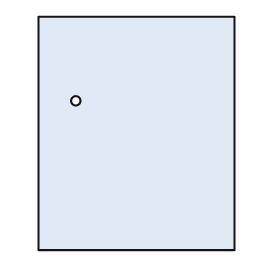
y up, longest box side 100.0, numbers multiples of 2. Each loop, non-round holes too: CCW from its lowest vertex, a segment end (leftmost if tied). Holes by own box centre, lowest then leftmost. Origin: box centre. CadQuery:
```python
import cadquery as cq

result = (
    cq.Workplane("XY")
    .moveTo(-42.0, -50.0)
    .lineTo(42.0, -50.0)
    .lineTo(42.0, 50.0)
    .lineTo(-42.0, 50.0)
    .close()
    .moveTo(-26.0, 14.0)
    .circle(2.0)
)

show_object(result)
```